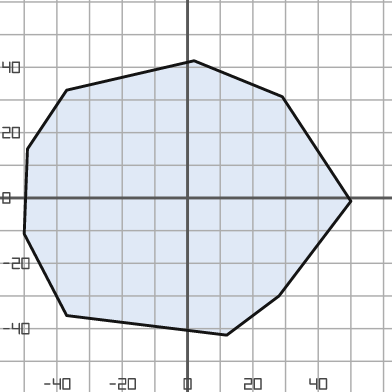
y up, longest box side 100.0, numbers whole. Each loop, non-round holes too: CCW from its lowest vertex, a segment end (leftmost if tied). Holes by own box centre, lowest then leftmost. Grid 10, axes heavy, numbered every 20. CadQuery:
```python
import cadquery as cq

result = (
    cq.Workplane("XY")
    .moveTo(12.0, -42.0)
    .lineTo(28.0, -30.0)
    .lineTo(50.0, -1.0)
    .lineTo(29.0, 31.0)
    .lineTo(2.0, 42.0)
    .lineTo(-37.0, 33.0)
    .lineTo(-49.0, 15.0)
    .lineTo(-50.0, -11.0)
    .lineTo(-37.0, -36.0)
    .close()
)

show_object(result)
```